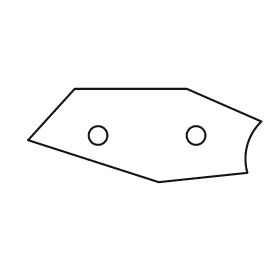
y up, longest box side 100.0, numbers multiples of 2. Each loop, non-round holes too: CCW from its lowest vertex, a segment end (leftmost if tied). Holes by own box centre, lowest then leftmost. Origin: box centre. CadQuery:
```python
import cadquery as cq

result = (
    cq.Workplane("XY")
    .moveTo(6.0, -20.0)
    .lineTo(44.0, -16.0)
    .threePointArc((44.0, -4.0), (50.0, 6.0))
    .lineTo(18.0, 20.0)
    .lineTo(-30.0, 20.0)
    .lineTo(-50.0, -2.0)
    .close()
    .moveTo(-20.0, 0.0)
    .circle(4.0)
    .moveTo(22.0, 0.0)
    .circle(4.0)
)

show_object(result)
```